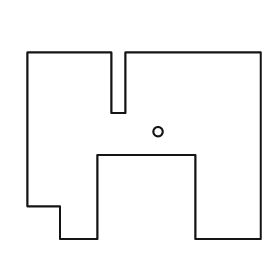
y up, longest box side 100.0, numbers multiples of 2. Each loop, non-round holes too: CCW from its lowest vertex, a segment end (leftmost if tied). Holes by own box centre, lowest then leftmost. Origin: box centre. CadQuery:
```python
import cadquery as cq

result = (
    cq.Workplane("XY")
    .moveTo(-36.0, -40.0)
    .lineTo(-20.0, -40.0)
    .lineTo(-20.0, -4.0)
    .lineTo(22.0, -4.0)
    .lineTo(22.0, -40.0)
    .lineTo(50.0, -40.0)
    .lineTo(50.0, 40.0)
    .lineTo(-8.0, 40.0)
    .lineTo(-8.0, 14.0)
    .lineTo(-14.0, 14.0)
    .lineTo(-14.0, 40.0)
    .lineTo(-50.0, 40.0)
    .lineTo(-50.0, -26.0)
    .lineTo(-36.0, -26.0)
    .close()
    .moveTo(6.0, 6.0)
    .circle(2.0)
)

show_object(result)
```